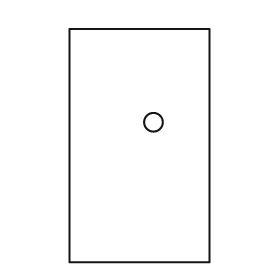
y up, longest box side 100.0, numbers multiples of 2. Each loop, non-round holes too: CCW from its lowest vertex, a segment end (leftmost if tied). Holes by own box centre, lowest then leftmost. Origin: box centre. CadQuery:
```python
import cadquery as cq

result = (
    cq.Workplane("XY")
    .moveTo(-30.0, -50.0)
    .lineTo(30.0, -50.0)
    .lineTo(30.0, 50.0)
    .lineTo(-30.0, 50.0)
    .close()
    .moveTo(6.0, 10.0)
    .circle(4.0)
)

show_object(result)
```